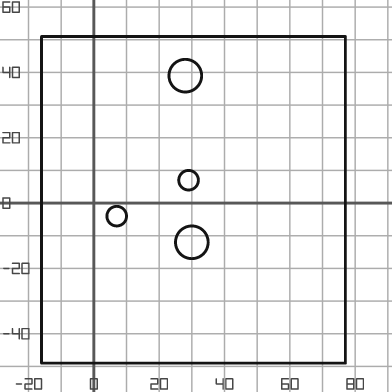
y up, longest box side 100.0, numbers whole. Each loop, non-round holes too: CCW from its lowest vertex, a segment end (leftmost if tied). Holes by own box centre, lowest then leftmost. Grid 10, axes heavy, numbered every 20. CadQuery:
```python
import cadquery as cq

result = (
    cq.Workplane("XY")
    .moveTo(-16.0, -49.0)
    .lineTo(77.0, -49.0)
    .lineTo(77.0, 51.0)
    .lineTo(-16.0, 51.0)
    .close()
    .moveTo(30.0, -12.0)
    .circle(5.0)
    .moveTo(7.0, -4.0)
    .circle(3.0)
    .moveTo(29.0, 7.0)
    .circle(3.0)
    .moveTo(28.0, 39.0)
    .circle(5.0)
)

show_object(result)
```